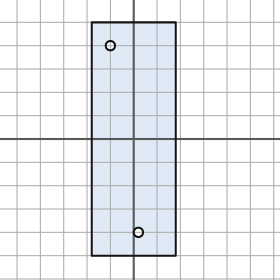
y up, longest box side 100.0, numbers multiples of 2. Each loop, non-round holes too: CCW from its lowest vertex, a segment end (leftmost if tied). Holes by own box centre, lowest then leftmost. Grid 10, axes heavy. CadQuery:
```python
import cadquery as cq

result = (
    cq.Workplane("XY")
    .moveTo(-18.0, -50.0)
    .lineTo(18.0, -50.0)
    .lineTo(18.0, 50.0)
    .lineTo(-18.0, 50.0)
    .close()
    .moveTo(2.0, -40.0)
    .circle(2.0)
    .moveTo(-10.0, 40.0)
    .circle(2.0)
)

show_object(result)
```